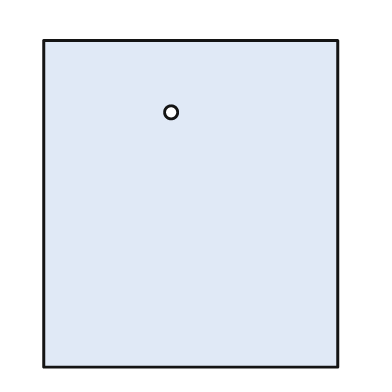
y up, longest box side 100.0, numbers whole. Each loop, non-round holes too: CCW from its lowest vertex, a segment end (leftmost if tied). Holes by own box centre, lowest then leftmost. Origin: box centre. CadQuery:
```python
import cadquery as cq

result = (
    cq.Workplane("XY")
    .moveTo(-45.0, -50.0)
    .lineTo(45.0, -50.0)
    .lineTo(45.0, 50.0)
    .lineTo(-45.0, 50.0)
    .close()
    .moveTo(-6.0, 28.0)
    .circle(2.0)
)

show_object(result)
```